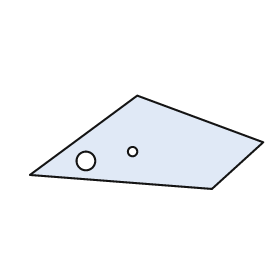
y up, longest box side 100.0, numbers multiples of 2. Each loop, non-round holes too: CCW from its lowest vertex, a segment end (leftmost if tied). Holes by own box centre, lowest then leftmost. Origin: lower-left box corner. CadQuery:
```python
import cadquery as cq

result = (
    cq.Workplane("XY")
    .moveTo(78.0, 0.0)
    .lineTo(100.0, 20.0)
    .lineTo(46.0, 40.0)
    .lineTo(0.0, 6.0)
    .close()
    .moveTo(24.0, 12.0)
    .circle(4.0)
    .moveTo(44.0, 16.0)
    .circle(2.0)
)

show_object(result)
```